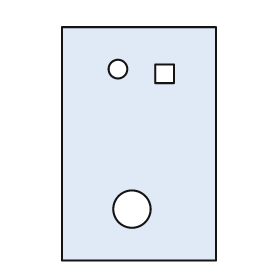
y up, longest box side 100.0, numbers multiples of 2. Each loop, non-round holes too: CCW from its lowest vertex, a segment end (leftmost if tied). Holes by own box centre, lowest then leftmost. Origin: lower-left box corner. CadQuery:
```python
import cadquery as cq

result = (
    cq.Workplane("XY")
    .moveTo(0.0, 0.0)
    .lineTo(66.0, 0.0)
    .lineTo(66.0, 100.0)
    .lineTo(0.0, 100.0)
    .close()
    .moveTo(30.0, 22.0)
    .circle(8.0)
    .moveTo(40.0, 76.0)
    .lineTo(48.0, 76.0)
    .lineTo(48.0, 84.0)
    .lineTo(40.0, 84.0)
    .close()
    .moveTo(24.0, 82.0)
    .circle(4.0)
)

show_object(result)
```